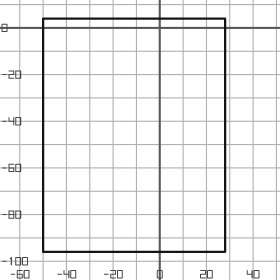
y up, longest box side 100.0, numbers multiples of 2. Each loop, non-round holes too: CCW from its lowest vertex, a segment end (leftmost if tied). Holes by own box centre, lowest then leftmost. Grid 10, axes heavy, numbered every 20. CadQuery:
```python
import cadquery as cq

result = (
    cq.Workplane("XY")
    .moveTo(-50.0, -96.0)
    .lineTo(28.0, -96.0)
    .lineTo(28.0, 4.0)
    .lineTo(-50.0, 4.0)
    .close()
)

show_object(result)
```